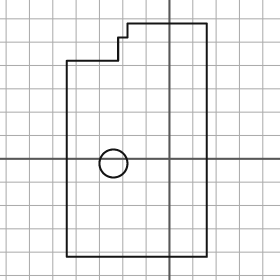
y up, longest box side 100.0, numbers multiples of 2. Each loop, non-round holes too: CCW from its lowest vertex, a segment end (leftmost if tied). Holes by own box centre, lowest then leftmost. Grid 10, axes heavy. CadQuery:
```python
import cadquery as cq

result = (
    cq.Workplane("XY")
    .moveTo(-44.0, -42.0)
    .lineTo(16.0, -42.0)
    .lineTo(16.0, 58.0)
    .lineTo(-18.0, 58.0)
    .lineTo(-18.0, 52.0)
    .lineTo(-22.0, 52.0)
    .lineTo(-22.0, 42.0)
    .lineTo(-44.0, 42.0)
    .close()
    .moveTo(-24.0, -2.0)
    .circle(6.0)
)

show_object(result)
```